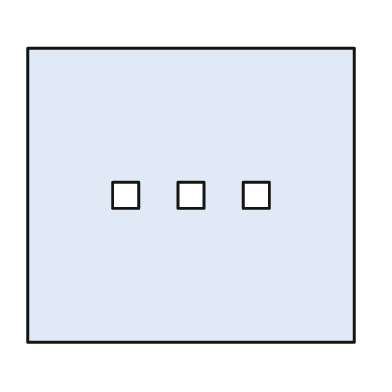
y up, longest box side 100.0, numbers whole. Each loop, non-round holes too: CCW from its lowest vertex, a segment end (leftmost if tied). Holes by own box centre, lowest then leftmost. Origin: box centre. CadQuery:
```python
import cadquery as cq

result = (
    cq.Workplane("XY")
    .moveTo(-50.0, -45.0)
    .lineTo(50.0, -45.0)
    .lineTo(50.0, 45.0)
    .lineTo(-50.0, 45.0)
    .close()
    .moveTo(-24.0, -4.0)
    .lineTo(-16.0, -4.0)
    .lineTo(-16.0, 4.0)
    .lineTo(-24.0, 4.0)
    .close()
    .moveTo(-4.0, -4.0)
    .lineTo(4.0, -4.0)
    .lineTo(4.0, 4.0)
    .lineTo(-4.0, 4.0)
    .close()
    .moveTo(16.0, -4.0)
    .lineTo(24.0, -4.0)
    .lineTo(24.0, 4.0)
    .lineTo(16.0, 4.0)
    .close()
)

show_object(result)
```